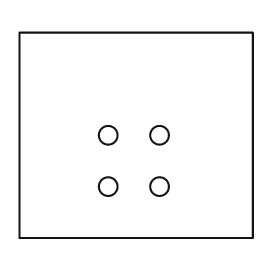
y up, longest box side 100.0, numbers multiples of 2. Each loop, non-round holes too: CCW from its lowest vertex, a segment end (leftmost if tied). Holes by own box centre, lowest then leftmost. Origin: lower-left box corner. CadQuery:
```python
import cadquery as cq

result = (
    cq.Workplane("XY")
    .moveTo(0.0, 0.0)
    .lineTo(100.0, 0.0)
    .lineTo(100.0, 88.0)
    .lineTo(0.0, 88.0)
    .close()
    .moveTo(38.0, 22.0)
    .circle(4.0)
    .moveTo(60.0, 22.0)
    .circle(4.0)
    .moveTo(38.0, 44.0)
    .circle(4.0)
    .moveTo(60.0, 44.0)
    .circle(4.0)
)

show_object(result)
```